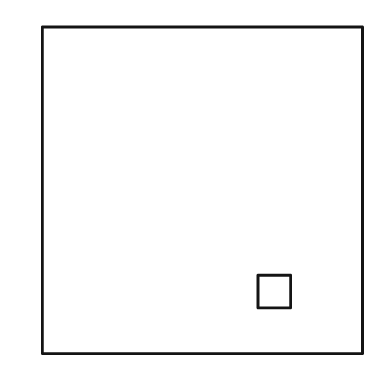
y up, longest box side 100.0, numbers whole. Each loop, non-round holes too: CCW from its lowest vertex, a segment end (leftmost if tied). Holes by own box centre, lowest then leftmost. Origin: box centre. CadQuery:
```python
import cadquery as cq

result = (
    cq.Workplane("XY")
    .moveTo(-49.0, -50.0)
    .lineTo(49.0, -50.0)
    .lineTo(49.0, 50.0)
    .lineTo(-49.0, 50.0)
    .close()
    .moveTo(17.0, -36.0)
    .lineTo(27.0, -36.0)
    .lineTo(27.0, -26.0)
    .lineTo(17.0, -26.0)
    .close()
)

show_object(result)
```